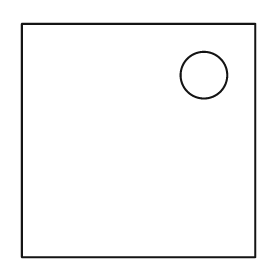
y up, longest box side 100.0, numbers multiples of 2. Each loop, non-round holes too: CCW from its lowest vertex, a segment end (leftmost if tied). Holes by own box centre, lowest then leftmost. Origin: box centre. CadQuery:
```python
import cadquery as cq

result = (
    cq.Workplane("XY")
    .moveTo(-50.0, -50.0)
    .lineTo(50.0, -50.0)
    .lineTo(50.0, 50.0)
    .lineTo(-50.0, 50.0)
    .close()
    .moveTo(28.0, 28.0)
    .circle(10.0)
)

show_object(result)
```